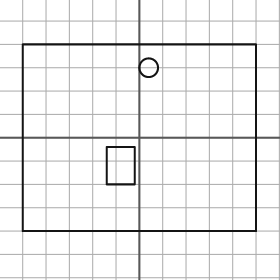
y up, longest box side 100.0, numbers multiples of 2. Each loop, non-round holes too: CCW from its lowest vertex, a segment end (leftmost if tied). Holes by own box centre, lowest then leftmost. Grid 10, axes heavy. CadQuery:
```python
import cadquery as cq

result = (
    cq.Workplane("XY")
    .moveTo(-50.0, -40.0)
    .lineTo(50.0, -40.0)
    .lineTo(50.0, 40.0)
    .lineTo(-50.0, 40.0)
    .close()
    .moveTo(-14.0, -20.0)
    .lineTo(-2.0, -20.0)
    .lineTo(-2.0, -4.0)
    .lineTo(-14.0, -4.0)
    .close()
    .moveTo(4.0, 30.0)
    .circle(4.0)
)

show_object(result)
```